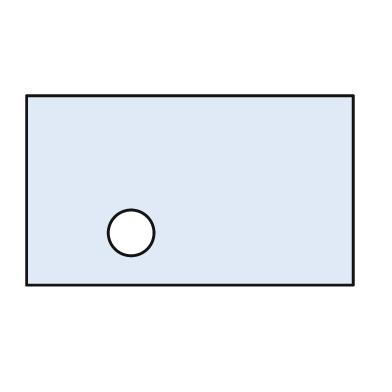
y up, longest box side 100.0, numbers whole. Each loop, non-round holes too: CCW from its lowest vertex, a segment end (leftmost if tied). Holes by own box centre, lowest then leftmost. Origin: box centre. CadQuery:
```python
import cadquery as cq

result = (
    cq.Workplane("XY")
    .moveTo(-50.0, -29.0)
    .lineTo(50.0, -29.0)
    .lineTo(50.0, 29.0)
    .lineTo(-50.0, 29.0)
    .close()
    .moveTo(-18.0, -13.0)
    .circle(7.0)
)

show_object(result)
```